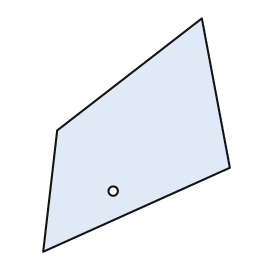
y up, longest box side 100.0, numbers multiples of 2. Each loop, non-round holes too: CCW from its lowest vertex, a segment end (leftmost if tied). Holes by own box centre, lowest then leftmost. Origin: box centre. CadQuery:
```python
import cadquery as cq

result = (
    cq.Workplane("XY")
    .moveTo(-40.0, -50.0)
    .lineTo(40.0, -14.0)
    .lineTo(28.0, 50.0)
    .lineTo(-34.0, 2.0)
    .close()
    .moveTo(-10.0, -24.0)
    .circle(2.0)
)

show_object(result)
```